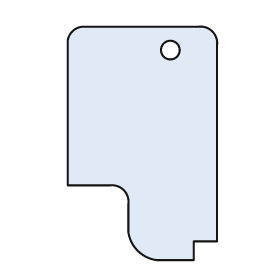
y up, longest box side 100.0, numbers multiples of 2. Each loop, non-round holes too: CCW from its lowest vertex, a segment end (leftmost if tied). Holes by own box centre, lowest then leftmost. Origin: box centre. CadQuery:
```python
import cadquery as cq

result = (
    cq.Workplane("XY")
    .moveTo(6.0, -50.0)
    .lineTo(22.0, -50.0)
    .lineTo(22.0, -42.0)
    .lineTo(32.0, -42.0)
    .lineTo(32.0, 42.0)
    .threePointArc((30.0, 48.0), (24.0, 50.0))
    .lineTo(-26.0, 50.0)
    .threePointArc((-30.0, 48.0), (-32.0, 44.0))
    .lineTo(-32.0, -18.0)
    .lineTo(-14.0, -18.0)
    .threePointArc((-8.0, -20.0), (-6.0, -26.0))
    .lineTo(-6.0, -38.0)
    .threePointArc((-2.0, -46.0), (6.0, -50.0))
    .close()
    .moveTo(12.0, 40.0)
    .circle(4.0)
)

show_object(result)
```